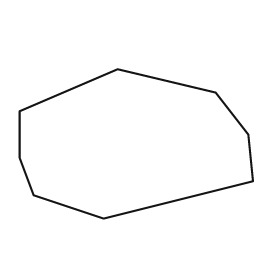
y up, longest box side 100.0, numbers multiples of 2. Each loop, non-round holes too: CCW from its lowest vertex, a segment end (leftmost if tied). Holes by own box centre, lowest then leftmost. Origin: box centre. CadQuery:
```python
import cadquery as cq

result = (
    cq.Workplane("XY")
    .moveTo(-14.0, -32.0)
    .lineTo(50.0, -16.0)
    .lineTo(48.0, 4.0)
    .lineTo(34.0, 22.0)
    .lineTo(-8.0, 32.0)
    .lineTo(-50.0, 14.0)
    .lineTo(-50.0, -6.0)
    .lineTo(-44.0, -22.0)
    .close()
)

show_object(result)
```